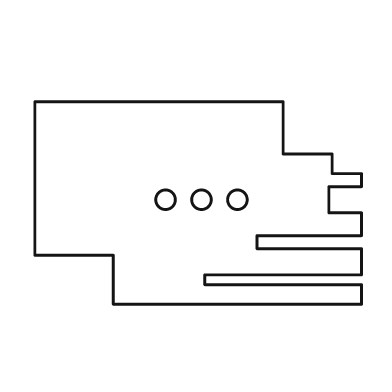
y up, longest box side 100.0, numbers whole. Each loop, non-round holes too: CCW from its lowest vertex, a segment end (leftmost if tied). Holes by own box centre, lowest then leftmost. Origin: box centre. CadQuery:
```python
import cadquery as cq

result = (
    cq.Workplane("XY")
    .moveTo(-26.0, -31.0)
    .lineTo(50.0, -31.0)
    .lineTo(50.0, -25.0)
    .lineTo(2.0, -25.0)
    .lineTo(2.0, -22.0)
    .lineTo(50.0, -22.0)
    .lineTo(50.0, -14.0)
    .lineTo(18.0, -14.0)
    .lineTo(18.0, -10.0)
    .lineTo(50.0, -10.0)
    .lineTo(50.0, -3.0)
    .lineTo(40.0, -3.0)
    .lineTo(40.0, 5.0)
    .lineTo(50.0, 5.0)
    .lineTo(50.0, 9.0)
    .lineTo(41.0, 9.0)
    .lineTo(41.0, 15.0)
    .lineTo(26.0, 15.0)
    .lineTo(26.0, 31.0)
    .lineTo(-50.0, 31.0)
    .lineTo(-50.0, -16.0)
    .lineTo(-26.0, -16.0)
    .close()
    .moveTo(-10.0, 1.0)
    .circle(3.0)
    .moveTo(1.0, 1.0)
    .circle(3.0)
    .moveTo(12.0, 1.0)
    .circle(3.0)
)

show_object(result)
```